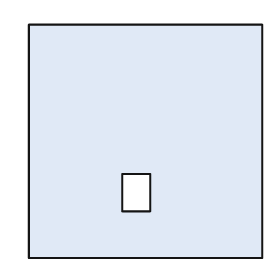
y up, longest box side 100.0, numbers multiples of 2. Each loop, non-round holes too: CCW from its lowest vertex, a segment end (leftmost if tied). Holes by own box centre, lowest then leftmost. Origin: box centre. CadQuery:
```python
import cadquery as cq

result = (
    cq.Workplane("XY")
    .moveTo(-50.0, -50.0)
    .lineTo(50.0, -50.0)
    .lineTo(50.0, 50.0)
    .lineTo(-50.0, 50.0)
    .close()
    .moveTo(-10.0, -30.0)
    .lineTo(2.0, -30.0)
    .lineTo(2.0, -14.0)
    .lineTo(-10.0, -14.0)
    .close()
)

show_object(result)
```